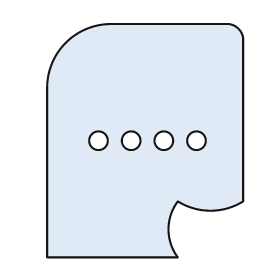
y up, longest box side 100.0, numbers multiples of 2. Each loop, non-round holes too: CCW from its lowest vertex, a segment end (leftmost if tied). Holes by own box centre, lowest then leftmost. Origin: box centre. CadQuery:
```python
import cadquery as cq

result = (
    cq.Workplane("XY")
    .moveTo(-42.0, -50.0)
    .lineTo(14.0, -50.0)
    .threePointArc((10.0, -38.0), (14.0, -26.0))
    .threePointArc((28.0, -30.0), (42.0, -26.0))
    .lineTo(42.0, 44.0)
    .threePointArc((40.0, 48.0), (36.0, 50.0))
    .lineTo(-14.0, 50.0)
    .threePointArc((-34.0, 42.0), (-42.0, 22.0))
    .close()
    .moveTo(-20.0, 0.0)
    .circle(4.0)
    .moveTo(-6.0, 0.0)
    .circle(4.0)
    .moveTo(8.0, 0.0)
    .circle(4.0)
    .moveTo(22.0, 0.0)
    .circle(4.0)
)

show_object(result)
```